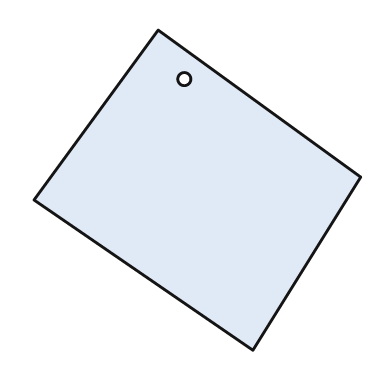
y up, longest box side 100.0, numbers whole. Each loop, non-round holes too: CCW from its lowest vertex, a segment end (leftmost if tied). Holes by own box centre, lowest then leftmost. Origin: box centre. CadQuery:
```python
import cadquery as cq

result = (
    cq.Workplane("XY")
    .moveTo(17.0, -49.0)
    .lineTo(50.0, 4.0)
    .lineTo(-12.0, 49.0)
    .lineTo(-50.0, -3.0)
    .close()
    .moveTo(-4.0, 34.0)
    .circle(2.0)
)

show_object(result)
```